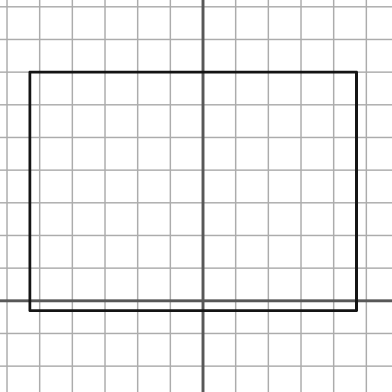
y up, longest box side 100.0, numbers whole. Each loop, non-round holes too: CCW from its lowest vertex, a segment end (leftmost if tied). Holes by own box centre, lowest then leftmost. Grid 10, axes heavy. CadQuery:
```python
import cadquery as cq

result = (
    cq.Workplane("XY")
    .moveTo(-53.0, -3.0)
    .lineTo(47.0, -3.0)
    .lineTo(47.0, 70.0)
    .lineTo(-53.0, 70.0)
    .close()
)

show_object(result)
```